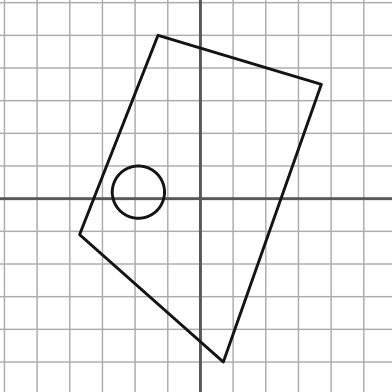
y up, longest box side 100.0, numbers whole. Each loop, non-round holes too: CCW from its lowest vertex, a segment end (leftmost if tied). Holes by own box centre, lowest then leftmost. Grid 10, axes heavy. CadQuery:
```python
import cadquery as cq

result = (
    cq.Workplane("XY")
    .moveTo(7.0, -50.0)
    .lineTo(37.0, 35.0)
    .lineTo(-13.0, 50.0)
    .lineTo(-37.0, -11.0)
    .close()
    .moveTo(-19.0, 2.0)
    .circle(8.0)
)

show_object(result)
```